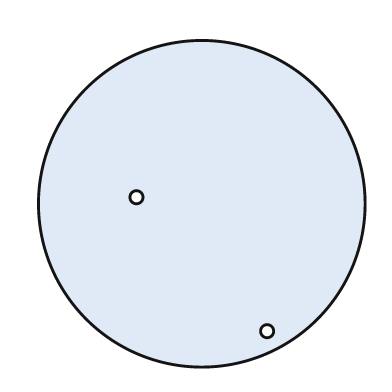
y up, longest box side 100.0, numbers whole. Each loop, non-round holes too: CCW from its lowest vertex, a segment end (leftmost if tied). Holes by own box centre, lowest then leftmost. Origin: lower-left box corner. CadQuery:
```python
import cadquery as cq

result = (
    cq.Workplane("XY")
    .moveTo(50.0, 50.0)
    .circle(50.0)
    .moveTo(70.0, 11.0)
    .circle(2.0)
    .moveTo(30.0, 52.0)
    .circle(2.0)
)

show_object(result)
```